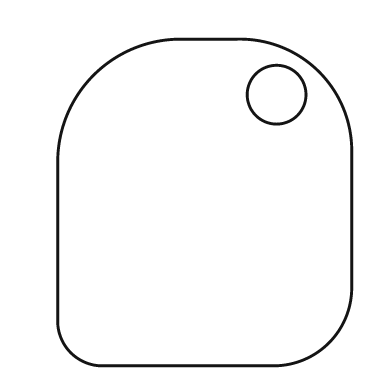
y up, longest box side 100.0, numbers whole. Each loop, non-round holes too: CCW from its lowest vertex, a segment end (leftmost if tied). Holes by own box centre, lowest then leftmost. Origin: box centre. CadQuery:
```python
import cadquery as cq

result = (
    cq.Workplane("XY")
    .moveTo(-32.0, -50.0)
    .lineTo(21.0, -50.0)
    .threePointArc((38.0, -43.0), (45.0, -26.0))
    .lineTo(45.0, 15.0)
    .threePointArc((35.0, 40.0), (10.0, 50.0))
    .lineTo(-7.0, 50.0)
    .threePointArc((-34.0, 39.0), (-45.0, 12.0))
    .lineTo(-45.0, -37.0)
    .threePointArc((-41.0, -46.0), (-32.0, -50.0))
    .close()
    .moveTo(22.0, 33.0)
    .circle(9.0)
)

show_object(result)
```